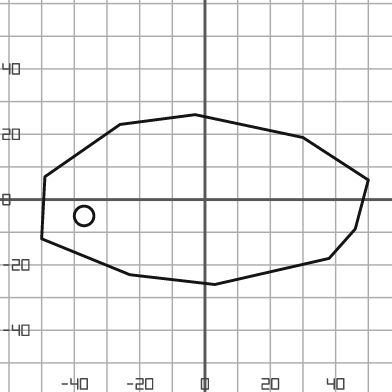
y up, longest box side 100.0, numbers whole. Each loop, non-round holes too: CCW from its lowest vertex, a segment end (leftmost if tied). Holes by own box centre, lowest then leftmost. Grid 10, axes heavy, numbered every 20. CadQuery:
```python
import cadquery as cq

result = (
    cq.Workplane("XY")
    .moveTo(3.0, -26.0)
    .lineTo(38.0, -18.0)
    .lineTo(46.0, -9.0)
    .lineTo(50.0, 6.0)
    .lineTo(30.0, 19.0)
    .lineTo(-3.0, 26.0)
    .lineTo(-26.0, 23.0)
    .lineTo(-49.0, 7.0)
    .lineTo(-50.0, -12.0)
    .lineTo(-23.0, -23.0)
    .close()
    .moveTo(-37.0, -5.0)
    .circle(3.0)
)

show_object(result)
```